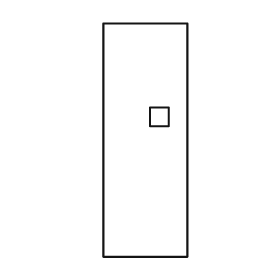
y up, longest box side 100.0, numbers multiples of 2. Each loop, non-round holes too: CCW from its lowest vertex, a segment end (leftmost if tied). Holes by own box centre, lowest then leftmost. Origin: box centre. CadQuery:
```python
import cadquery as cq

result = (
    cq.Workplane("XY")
    .moveTo(-18.0, -50.0)
    .lineTo(18.0, -50.0)
    .lineTo(18.0, 50.0)
    .lineTo(-18.0, 50.0)
    .close()
    .moveTo(2.0, 6.0)
    .lineTo(10.0, 6.0)
    .lineTo(10.0, 14.0)
    .lineTo(2.0, 14.0)
    .close()
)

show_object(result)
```